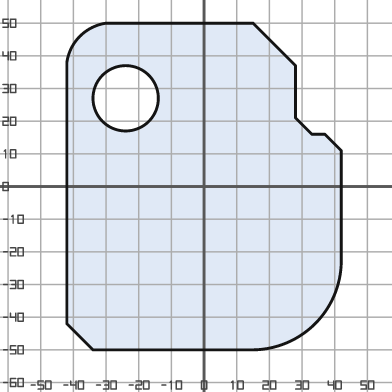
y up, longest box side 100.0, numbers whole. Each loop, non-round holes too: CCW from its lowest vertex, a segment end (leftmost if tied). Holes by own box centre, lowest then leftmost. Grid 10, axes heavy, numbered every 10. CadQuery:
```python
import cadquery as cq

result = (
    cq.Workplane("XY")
    .moveTo(-34.0, -50.0)
    .lineTo(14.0, -50.0)
    .threePointArc((34.0, -42.0), (42.0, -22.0))
    .lineTo(42.0, 11.0)
    .lineTo(37.0, 16.0)
    .lineTo(33.0, 16.0)
    .lineTo(28.0, 21.0)
    .lineTo(28.0, 37.0)
    .lineTo(15.0, 50.0)
    .lineTo(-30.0, 50.0)
    .threePointArc((-38.0, 46.0), (-42.0, 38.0))
    .lineTo(-42.0, -42.0)
    .close()
    .moveTo(-24.0, 27.0)
    .circle(10.0)
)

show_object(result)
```